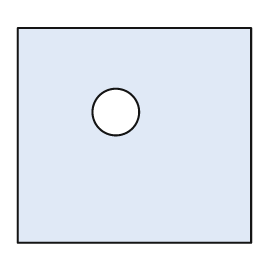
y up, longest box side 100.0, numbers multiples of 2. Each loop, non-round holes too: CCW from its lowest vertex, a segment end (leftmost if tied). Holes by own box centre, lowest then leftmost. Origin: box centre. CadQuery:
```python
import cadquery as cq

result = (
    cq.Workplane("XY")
    .moveTo(-50.0, -46.0)
    .lineTo(50.0, -46.0)
    .lineTo(50.0, 46.0)
    .lineTo(-50.0, 46.0)
    .close()
    .moveTo(-8.0, 10.0)
    .circle(10.0)
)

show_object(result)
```